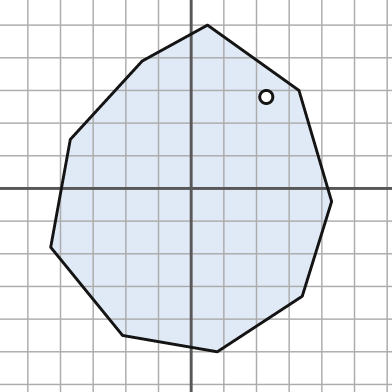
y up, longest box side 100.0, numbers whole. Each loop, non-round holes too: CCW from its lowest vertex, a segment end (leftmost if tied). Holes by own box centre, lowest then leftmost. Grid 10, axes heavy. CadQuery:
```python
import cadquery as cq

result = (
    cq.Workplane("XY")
    .moveTo(8.0, -50.0)
    .lineTo(34.0, -33.0)
    .lineTo(43.0, -4.0)
    .lineTo(33.0, 30.0)
    .lineTo(5.0, 50.0)
    .lineTo(-15.0, 39.0)
    .lineTo(-37.0, 15.0)
    .lineTo(-43.0, -18.0)
    .lineTo(-21.0, -45.0)
    .close()
    .moveTo(23.0, 28.0)
    .circle(2.0)
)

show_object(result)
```